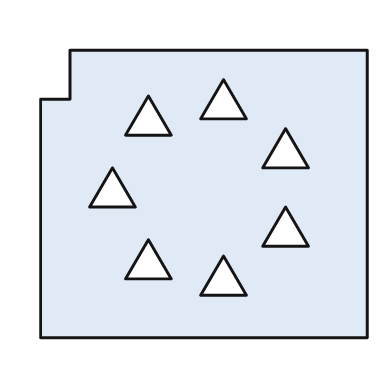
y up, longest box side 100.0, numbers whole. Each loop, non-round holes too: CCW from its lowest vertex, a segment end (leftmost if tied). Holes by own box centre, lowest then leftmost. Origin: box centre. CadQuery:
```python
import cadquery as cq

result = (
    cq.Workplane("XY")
    .moveTo(-50.0, -44.0)
    .lineTo(50.0, -44.0)
    .lineTo(50.0, 44.0)
    .lineTo(-41.0, 44.0)
    .lineTo(-41.0, 29.0)
    .lineTo(-50.0, 29.0)
    .close()
    .moveTo(-1.0, -31.0)
    .lineTo(13.0, -31.0)
    .lineTo(6.0, -19.0)
    .close()
    .moveTo(-24.0, -26.0)
    .lineTo(-10.0, -26.0)
    .lineTo(-17.0, -14.0)
    .close()
    .moveTo(18.0, -16.0)
    .lineTo(32.0, -16.0)
    .lineTo(25.0, -4.0)
    .close()
    .moveTo(-35.0, -4.0)
    .lineTo(-21.0, -4.0)
    .lineTo(-28.0, 8.0)
    .close()
    .moveTo(18.0, 8.0)
    .lineTo(32.0, 8.0)
    .lineTo(25.0, 20.0)
    .close()
    .moveTo(-24.0, 18.0)
    .lineTo(-10.0, 18.0)
    .lineTo(-17.0, 30.0)
    .close()
    .moveTo(-1.0, 23.0)
    .lineTo(13.0, 23.0)
    .lineTo(6.0, 35.0)
    .close()
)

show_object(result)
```